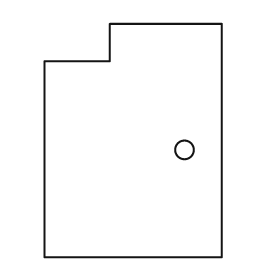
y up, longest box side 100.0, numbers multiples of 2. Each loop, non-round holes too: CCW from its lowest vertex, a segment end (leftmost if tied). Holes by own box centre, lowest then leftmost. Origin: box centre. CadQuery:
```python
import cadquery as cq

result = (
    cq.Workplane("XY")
    .moveTo(-38.0, -50.0)
    .lineTo(38.0, -50.0)
    .lineTo(38.0, 50.0)
    .lineTo(-10.0, 50.0)
    .lineTo(-10.0, 34.0)
    .lineTo(-38.0, 34.0)
    .close()
    .moveTo(22.0, -4.0)
    .circle(4.0)
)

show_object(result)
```